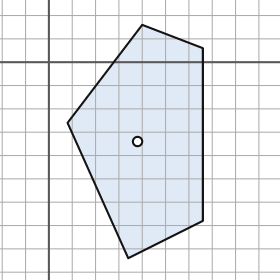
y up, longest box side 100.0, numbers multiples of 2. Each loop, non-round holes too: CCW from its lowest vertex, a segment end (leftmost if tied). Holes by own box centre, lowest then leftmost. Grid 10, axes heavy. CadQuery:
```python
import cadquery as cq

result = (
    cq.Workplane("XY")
    .moveTo(34.0, -84.0)
    .lineTo(66.0, -68.0)
    .lineTo(66.0, 6.0)
    .lineTo(40.0, 16.0)
    .lineTo(8.0, -26.0)
    .close()
    .moveTo(38.0, -34.0)
    .circle(2.0)
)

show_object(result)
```